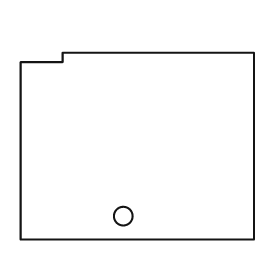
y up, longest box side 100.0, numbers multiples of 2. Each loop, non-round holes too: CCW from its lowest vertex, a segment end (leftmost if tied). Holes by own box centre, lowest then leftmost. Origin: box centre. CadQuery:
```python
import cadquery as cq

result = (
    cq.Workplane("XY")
    .moveTo(-50.0, -40.0)
    .lineTo(50.0, -40.0)
    .lineTo(50.0, 40.0)
    .lineTo(-32.0, 40.0)
    .lineTo(-32.0, 36.0)
    .lineTo(-50.0, 36.0)
    .close()
    .moveTo(-6.0, -30.0)
    .circle(4.0)
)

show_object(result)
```